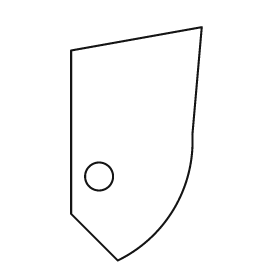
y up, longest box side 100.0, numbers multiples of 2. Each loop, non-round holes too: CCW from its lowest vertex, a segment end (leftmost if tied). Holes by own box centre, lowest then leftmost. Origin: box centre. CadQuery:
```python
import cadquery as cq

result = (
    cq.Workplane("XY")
    .moveTo(-8.0, -50.0)
    .threePointArc((16.0, -28.0), (24.0, 4.0))
    .lineTo(28.0, 50.0)
    .lineTo(-28.0, 40.0)
    .lineTo(-28.0, -30.0)
    .close()
    .moveTo(-16.0, -14.0)
    .circle(6.0)
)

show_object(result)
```